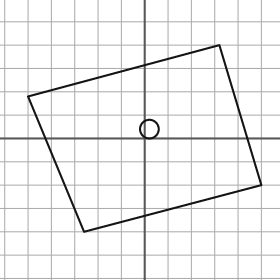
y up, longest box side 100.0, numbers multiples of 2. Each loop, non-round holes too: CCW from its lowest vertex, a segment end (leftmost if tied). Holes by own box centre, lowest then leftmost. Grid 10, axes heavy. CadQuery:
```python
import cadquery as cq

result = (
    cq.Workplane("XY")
    .moveTo(-26.0, -40.0)
    .lineTo(50.0, -20.0)
    .lineTo(32.0, 40.0)
    .lineTo(-50.0, 18.0)
    .close()
    .moveTo(2.0, 4.0)
    .circle(4.0)
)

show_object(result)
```